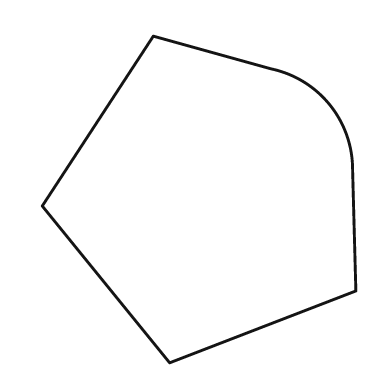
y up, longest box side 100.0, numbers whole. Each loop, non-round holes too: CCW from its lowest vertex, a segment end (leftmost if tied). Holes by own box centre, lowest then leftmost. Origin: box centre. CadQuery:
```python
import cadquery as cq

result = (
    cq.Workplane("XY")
    .moveTo(-9.0, -50.0)
    .lineTo(48.0, -28.0)
    .lineTo(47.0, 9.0)
    .threePointArc((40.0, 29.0), (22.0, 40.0))
    .lineTo(-14.0, 50.0)
    .lineTo(-48.0, -2.0)
    .close()
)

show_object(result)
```